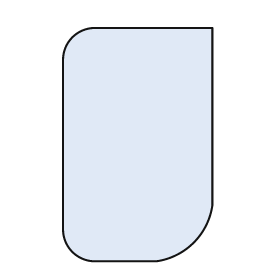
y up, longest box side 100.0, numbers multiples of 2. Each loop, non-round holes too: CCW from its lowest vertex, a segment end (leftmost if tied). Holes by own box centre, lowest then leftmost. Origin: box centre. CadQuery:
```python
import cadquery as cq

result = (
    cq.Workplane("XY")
    .moveTo(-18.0, -50.0)
    .lineTo(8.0, -50.0)
    .threePointArc((24.0, -42.0), (32.0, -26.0))
    .lineTo(32.0, 50.0)
    .lineTo(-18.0, 50.0)
    .threePointArc((-28.0, 46.0), (-32.0, 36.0))
    .lineTo(-32.0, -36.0)
    .threePointArc((-28.0, -46.0), (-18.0, -50.0))
    .close()
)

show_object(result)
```